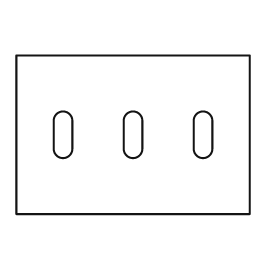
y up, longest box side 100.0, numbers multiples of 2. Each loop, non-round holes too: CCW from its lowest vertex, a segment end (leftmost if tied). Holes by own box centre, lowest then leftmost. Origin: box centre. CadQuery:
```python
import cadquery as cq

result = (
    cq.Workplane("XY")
    .moveTo(-50.0, -34.0)
    .lineTo(50.0, -34.0)
    .lineTo(50.0, 34.0)
    .lineTo(-50.0, 34.0)
    .close()
    .moveTo(-34.0, -6.0)
    .threePointArc((-30.0, -10.0), (-26.0, -6.0))
    .lineTo(-26.0, 6.0)
    .threePointArc((-30.0, 10.0), (-34.0, 6.0))
    .close()
    .moveTo(-4.0, -6.0)
    .threePointArc((0.0, -10.0), (4.0, -6.0))
    .lineTo(4.0, 6.0)
    .threePointArc((0.0, 10.0), (-4.0, 6.0))
    .close()
    .moveTo(26.0, -6.0)
    .threePointArc((30.0, -10.0), (34.0, -6.0))
    .lineTo(34.0, 6.0)
    .threePointArc((30.0, 10.0), (26.0, 6.0))
    .close()
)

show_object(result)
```